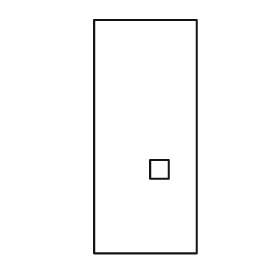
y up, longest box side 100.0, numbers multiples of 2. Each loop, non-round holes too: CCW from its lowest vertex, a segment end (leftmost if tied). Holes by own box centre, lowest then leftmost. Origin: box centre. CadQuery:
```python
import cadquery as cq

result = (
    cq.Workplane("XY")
    .moveTo(-22.0, -50.0)
    .lineTo(22.0, -50.0)
    .lineTo(22.0, 50.0)
    .lineTo(-22.0, 50.0)
    .close()
    .moveTo(2.0, -18.0)
    .lineTo(10.0, -18.0)
    .lineTo(10.0, -10.0)
    .lineTo(2.0, -10.0)
    .close()
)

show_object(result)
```